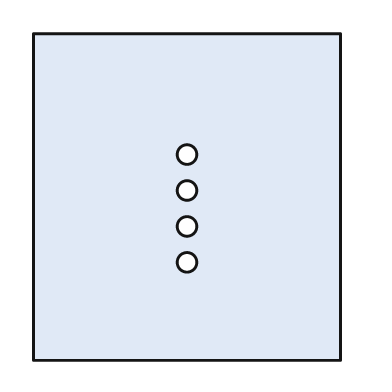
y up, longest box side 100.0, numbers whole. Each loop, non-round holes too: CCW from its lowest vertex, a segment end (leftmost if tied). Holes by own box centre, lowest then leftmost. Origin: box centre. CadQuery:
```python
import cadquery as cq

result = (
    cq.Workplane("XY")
    .moveTo(-47.0, -50.0)
    .lineTo(47.0, -50.0)
    .lineTo(47.0, 50.0)
    .lineTo(-47.0, 50.0)
    .close()
    .moveTo(0.0, -20.0)
    .circle(3.0)
    .moveTo(0.0, -9.0)
    .circle(3.0)
    .moveTo(0.0, 2.0)
    .circle(3.0)
    .moveTo(0.0, 13.0)
    .circle(3.0)
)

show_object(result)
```